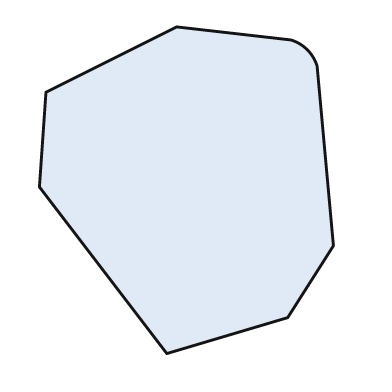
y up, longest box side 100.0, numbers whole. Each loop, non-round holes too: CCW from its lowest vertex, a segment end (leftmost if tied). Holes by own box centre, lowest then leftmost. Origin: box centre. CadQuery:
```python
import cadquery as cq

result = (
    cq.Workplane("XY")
    .moveTo(-6.0, -50.0)
    .lineTo(31.0, -39.0)
    .lineTo(45.0, -17.0)
    .lineTo(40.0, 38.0)
    .threePointArc((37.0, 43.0), (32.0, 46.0))
    .lineTo(-3.0, 50.0)
    .lineTo(-43.0, 30.0)
    .lineTo(-45.0, 1.0)
    .close()
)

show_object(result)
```